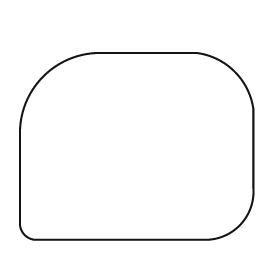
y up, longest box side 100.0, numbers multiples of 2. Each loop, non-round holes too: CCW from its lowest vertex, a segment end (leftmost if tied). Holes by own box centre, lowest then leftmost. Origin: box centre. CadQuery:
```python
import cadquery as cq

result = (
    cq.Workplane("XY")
    .moveTo(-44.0, -40.0)
    .lineTo(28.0, -40.0)
    .threePointArc((44.0, -34.0), (50.0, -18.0))
    .lineTo(50.0, 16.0)
    .threePointArc((42.0, 32.0), (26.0, 40.0))
    .lineTo(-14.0, 40.0)
    .threePointArc((-40.0, 30.0), (-50.0, 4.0))
    .lineTo(-50.0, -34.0)
    .threePointArc((-48.0, -38.0), (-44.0, -40.0))
    .close()
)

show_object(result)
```